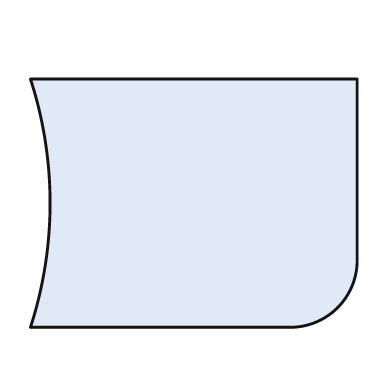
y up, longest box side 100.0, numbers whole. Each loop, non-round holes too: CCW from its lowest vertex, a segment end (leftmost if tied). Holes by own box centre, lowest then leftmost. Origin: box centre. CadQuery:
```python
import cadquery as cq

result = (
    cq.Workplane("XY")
    .moveTo(-50.0, -38.0)
    .lineTo(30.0, -38.0)
    .threePointArc((44.0, -32.0), (50.0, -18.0))
    .lineTo(50.0, 38.0)
    .lineTo(-50.0, 38.0)
    .threePointArc((-44.0, 0.0), (-50.0, -38.0))
    .close()
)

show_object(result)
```